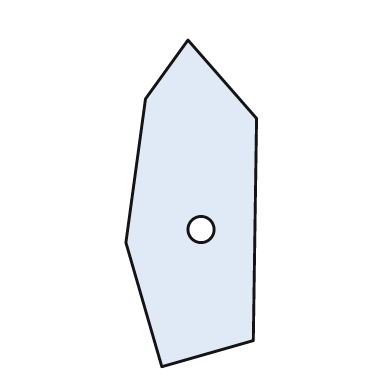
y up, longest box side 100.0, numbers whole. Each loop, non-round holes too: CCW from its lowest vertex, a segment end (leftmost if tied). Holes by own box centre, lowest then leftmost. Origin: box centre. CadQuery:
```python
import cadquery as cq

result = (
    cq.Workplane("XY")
    .moveTo(-9.0, -50.0)
    .lineTo(19.0, -42.0)
    .lineTo(20.0, 26.0)
    .lineTo(-1.0, 50.0)
    .lineTo(-14.0, 32.0)
    .lineTo(-20.0, -12.0)
    .close()
    .moveTo(3.0, -8.0)
    .circle(4.0)
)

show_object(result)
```